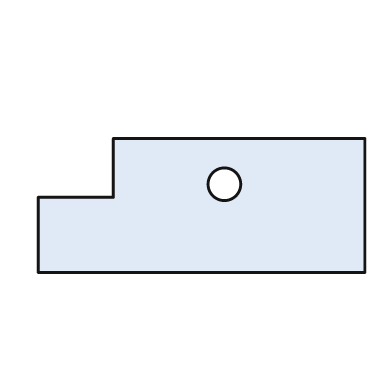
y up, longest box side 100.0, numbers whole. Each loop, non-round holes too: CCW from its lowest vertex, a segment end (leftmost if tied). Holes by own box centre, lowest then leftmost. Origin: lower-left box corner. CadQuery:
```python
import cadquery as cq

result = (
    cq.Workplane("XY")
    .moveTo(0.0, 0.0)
    .lineTo(100.0, 0.0)
    .lineTo(100.0, 41.0)
    .lineTo(23.0, 41.0)
    .lineTo(23.0, 23.0)
    .lineTo(0.0, 23.0)
    .close()
    .moveTo(57.0, 27.0)
    .circle(5.0)
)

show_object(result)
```